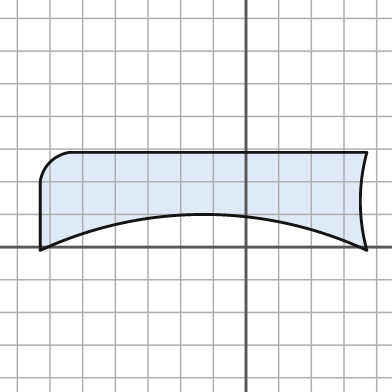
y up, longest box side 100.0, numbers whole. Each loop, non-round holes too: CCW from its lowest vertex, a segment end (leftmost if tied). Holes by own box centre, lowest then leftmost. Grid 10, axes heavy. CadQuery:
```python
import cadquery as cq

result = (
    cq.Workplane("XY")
    .moveTo(-63.0, -1.0)
    .threePointArc((-13.0, 10.0), (37.0, -1.0))
    .threePointArc((35.0, 14.0), (37.0, 29.0))
    .lineTo(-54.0, 29.0)
    .threePointArc((-60.0, 26.0), (-63.0, 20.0))
    .close()
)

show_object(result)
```